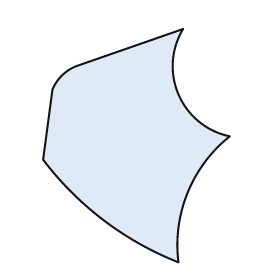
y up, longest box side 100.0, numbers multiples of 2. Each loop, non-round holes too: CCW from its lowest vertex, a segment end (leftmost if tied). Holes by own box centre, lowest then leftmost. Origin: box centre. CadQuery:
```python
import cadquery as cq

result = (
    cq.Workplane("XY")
    .moveTo(18.0, -50.0)
    .threePointArc((22.0, -20.0), (40.0, 4.0))
    .threePointArc((18.0, 22.0), (20.0, 50.0))
    .lineTo(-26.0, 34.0)
    .threePointArc((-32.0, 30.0), (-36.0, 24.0))
    .lineTo(-40.0, -6.0)
    .threePointArc((-14.0, -32.0), (18.0, -50.0))
    .close()
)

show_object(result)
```